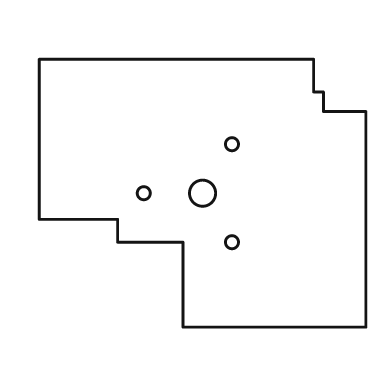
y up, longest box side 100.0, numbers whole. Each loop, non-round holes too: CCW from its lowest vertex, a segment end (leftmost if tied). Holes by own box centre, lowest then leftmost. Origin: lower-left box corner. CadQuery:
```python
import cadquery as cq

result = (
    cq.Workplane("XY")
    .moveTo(44.0, 0.0)
    .lineTo(100.0, 0.0)
    .lineTo(100.0, 66.0)
    .lineTo(87.0, 66.0)
    .lineTo(87.0, 72.0)
    .lineTo(84.0, 72.0)
    .lineTo(84.0, 82.0)
    .lineTo(0.0, 82.0)
    .lineTo(0.0, 33.0)
    .lineTo(24.0, 33.0)
    .lineTo(24.0, 26.0)
    .lineTo(44.0, 26.0)
    .close()
    .moveTo(59.0, 26.0)
    .circle(2.0)
    .moveTo(32.0, 41.0)
    .circle(2.0)
    .moveTo(50.0, 41.0)
    .circle(4.0)
    .moveTo(59.0, 56.0)
    .circle(2.0)
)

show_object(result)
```